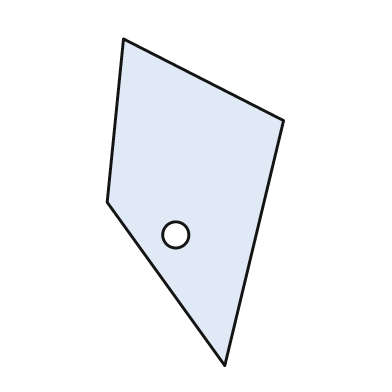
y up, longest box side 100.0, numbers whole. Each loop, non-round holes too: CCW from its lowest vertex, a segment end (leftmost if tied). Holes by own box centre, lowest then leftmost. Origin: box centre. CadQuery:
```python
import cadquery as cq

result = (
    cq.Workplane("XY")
    .moveTo(9.0, -50.0)
    .lineTo(27.0, 25.0)
    .lineTo(-22.0, 50.0)
    .lineTo(-27.0, 0.0)
    .close()
    .moveTo(-6.0, -10.0)
    .circle(4.0)
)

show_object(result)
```